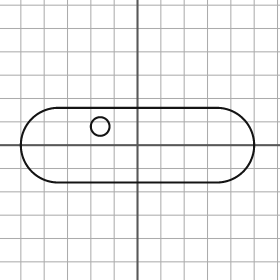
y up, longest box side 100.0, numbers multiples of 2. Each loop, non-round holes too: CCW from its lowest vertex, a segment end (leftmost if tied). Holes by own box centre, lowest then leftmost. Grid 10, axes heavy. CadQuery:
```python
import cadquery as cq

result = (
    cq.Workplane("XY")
    .moveTo(-34.0, -16.0)
    .lineTo(34.0, -16.0)
    .threePointArc((50.0, 0.0), (34.0, 16.0))
    .lineTo(-34.0, 16.0)
    .threePointArc((-50.0, 0.0), (-34.0, -16.0))
    .close()
    .moveTo(-16.0, 8.0)
    .circle(4.0)
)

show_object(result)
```